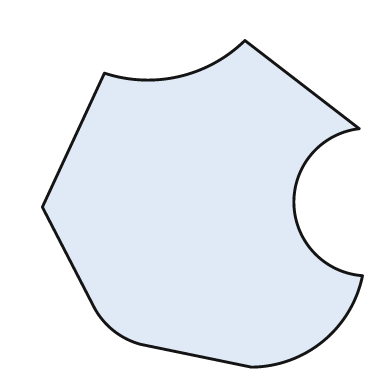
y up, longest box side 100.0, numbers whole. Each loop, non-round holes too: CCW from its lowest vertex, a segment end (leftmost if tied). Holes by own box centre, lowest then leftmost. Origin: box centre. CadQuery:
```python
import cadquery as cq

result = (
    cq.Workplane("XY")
    .moveTo(15.0, -50.0)
    .threePointArc((37.0, -42.0), (49.0, -22.0))
    .threePointArc((28.0, 0.0), (48.0, 23.0))
    .lineTo(13.0, 50.0)
    .threePointArc((-7.0, 39.0), (-30.0, 40.0))
    .lineTo(-49.0, -1.0)
    .lineTo(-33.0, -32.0)
    .threePointArc((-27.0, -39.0), (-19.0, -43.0))
    .close()
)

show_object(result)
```